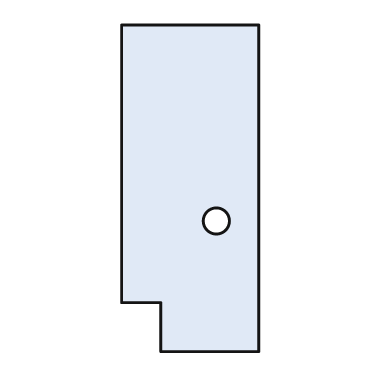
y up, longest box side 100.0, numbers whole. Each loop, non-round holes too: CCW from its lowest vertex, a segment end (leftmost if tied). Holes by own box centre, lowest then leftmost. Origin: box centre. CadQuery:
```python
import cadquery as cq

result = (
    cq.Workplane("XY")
    .moveTo(-9.0, -50.0)
    .lineTo(21.0, -50.0)
    .lineTo(21.0, 50.0)
    .lineTo(-21.0, 50.0)
    .lineTo(-21.0, -35.0)
    .lineTo(-9.0, -35.0)
    .close()
    .moveTo(8.0, -10.0)
    .circle(4.0)
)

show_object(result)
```